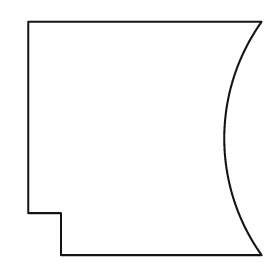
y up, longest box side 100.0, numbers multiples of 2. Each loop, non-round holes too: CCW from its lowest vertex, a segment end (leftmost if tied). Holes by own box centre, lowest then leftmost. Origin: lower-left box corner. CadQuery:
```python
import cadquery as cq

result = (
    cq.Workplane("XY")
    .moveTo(14.0, 0.0)
    .lineTo(100.0, 0.0)
    .threePointArc((84.0, 50.0), (100.0, 100.0))
    .lineTo(0.0, 100.0)
    .lineTo(0.0, 18.0)
    .lineTo(14.0, 18.0)
    .close()
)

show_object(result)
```